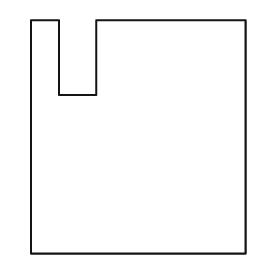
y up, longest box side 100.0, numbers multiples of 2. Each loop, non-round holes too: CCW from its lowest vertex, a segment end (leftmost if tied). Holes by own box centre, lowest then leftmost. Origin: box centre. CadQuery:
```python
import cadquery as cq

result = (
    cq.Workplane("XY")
    .moveTo(-46.0, -50.0)
    .lineTo(46.0, -50.0)
    .lineTo(46.0, 50.0)
    .lineTo(-18.0, 50.0)
    .lineTo(-18.0, 18.0)
    .lineTo(-34.0, 18.0)
    .lineTo(-34.0, 50.0)
    .lineTo(-46.0, 50.0)
    .close()
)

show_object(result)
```